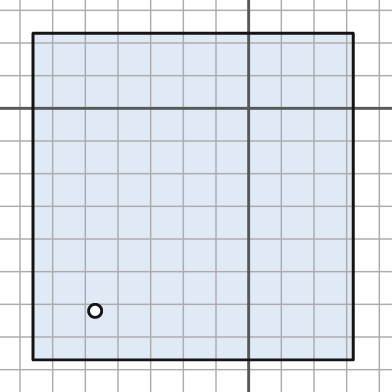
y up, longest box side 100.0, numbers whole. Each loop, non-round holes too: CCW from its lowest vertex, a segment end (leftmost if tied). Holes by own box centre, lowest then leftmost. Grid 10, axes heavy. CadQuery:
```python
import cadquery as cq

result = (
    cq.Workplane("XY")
    .moveTo(-66.0, -77.0)
    .lineTo(32.0, -77.0)
    .lineTo(32.0, 23.0)
    .lineTo(-66.0, 23.0)
    .close()
    .moveTo(-47.0, -62.0)
    .circle(2.0)
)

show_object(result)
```